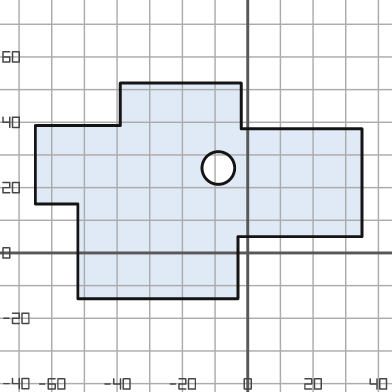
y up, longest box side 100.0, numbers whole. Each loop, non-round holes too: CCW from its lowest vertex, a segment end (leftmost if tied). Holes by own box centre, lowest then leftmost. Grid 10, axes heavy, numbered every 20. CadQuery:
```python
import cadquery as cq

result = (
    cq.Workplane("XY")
    .moveTo(-52.0, -14.0)
    .lineTo(-3.0, -14.0)
    .lineTo(-3.0, 5.0)
    .lineTo(35.0, 5.0)
    .lineTo(35.0, 38.0)
    .lineTo(-2.0, 38.0)
    .lineTo(-2.0, 52.0)
    .lineTo(-39.0, 52.0)
    .lineTo(-39.0, 39.0)
    .lineTo(-65.0, 39.0)
    .lineTo(-65.0, 15.0)
    .lineTo(-52.0, 15.0)
    .close()
    .moveTo(-9.0, 26.0)
    .circle(5.0)
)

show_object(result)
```